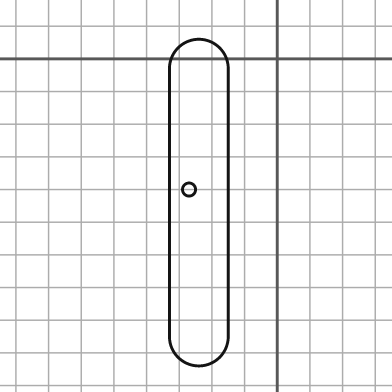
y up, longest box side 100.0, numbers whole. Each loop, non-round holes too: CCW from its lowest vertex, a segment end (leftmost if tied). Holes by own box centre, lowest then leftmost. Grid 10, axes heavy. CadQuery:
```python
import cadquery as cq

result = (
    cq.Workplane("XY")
    .moveTo(-33.0, -85.0)
    .threePointArc((-24.0, -94.0), (-15.0, -85.0))
    .lineTo(-15.0, -3.0)
    .threePointArc((-24.0, 6.0), (-33.0, -3.0))
    .close()
    .moveTo(-27.0, -40.0)
    .circle(2.0)
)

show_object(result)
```